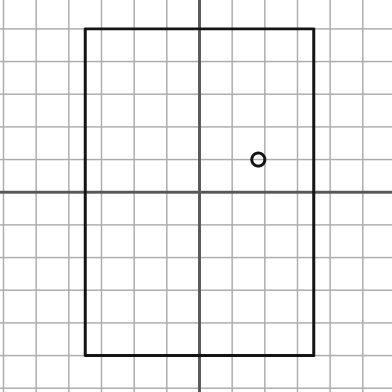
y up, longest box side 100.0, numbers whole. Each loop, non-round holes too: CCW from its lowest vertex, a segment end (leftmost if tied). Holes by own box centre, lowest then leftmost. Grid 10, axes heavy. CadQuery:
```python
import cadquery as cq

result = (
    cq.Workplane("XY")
    .moveTo(-35.0, -50.0)
    .lineTo(35.0, -50.0)
    .lineTo(35.0, 50.0)
    .lineTo(-35.0, 50.0)
    .close()
    .moveTo(18.0, 10.0)
    .circle(2.0)
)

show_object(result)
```